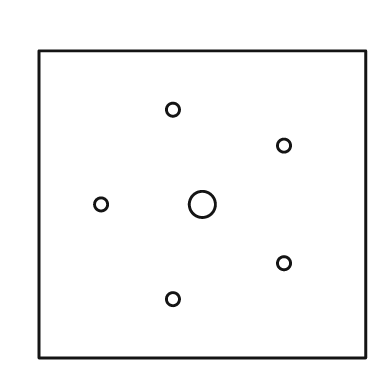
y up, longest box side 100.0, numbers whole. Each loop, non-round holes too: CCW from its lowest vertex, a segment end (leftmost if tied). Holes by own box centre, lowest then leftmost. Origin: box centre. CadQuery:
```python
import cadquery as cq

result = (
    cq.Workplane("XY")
    .moveTo(-50.0, -47.0)
    .lineTo(50.0, -47.0)
    .lineTo(50.0, 47.0)
    .lineTo(-50.0, 47.0)
    .close()
    .moveTo(-9.0, -29.0)
    .circle(2.0)
    .moveTo(25.0, -18.0)
    .circle(2.0)
    .moveTo(-31.0, 0.0)
    .circle(2.0)
    .moveTo(0.0, 0.0)
    .circle(4.0)
    .moveTo(25.0, 18.0)
    .circle(2.0)
    .moveTo(-9.0, 29.0)
    .circle(2.0)
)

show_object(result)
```